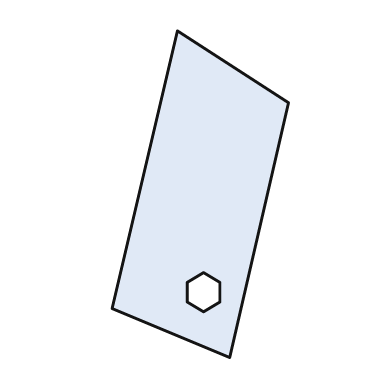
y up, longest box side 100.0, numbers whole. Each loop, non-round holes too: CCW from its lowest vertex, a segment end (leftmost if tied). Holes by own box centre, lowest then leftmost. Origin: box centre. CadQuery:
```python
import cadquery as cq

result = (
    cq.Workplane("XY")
    .moveTo(9.0, -50.0)
    .lineTo(27.0, 28.0)
    .lineTo(-7.0, 50.0)
    .lineTo(-27.0, -35.0)
    .close()
    .moveTo(1.0, -36.0)
    .lineTo(6.0, -33.0)
    .lineTo(6.0, -27.0)
    .lineTo(1.0, -24.0)
    .lineTo(-4.0, -27.0)
    .lineTo(-4.0, -33.0)
    .close()
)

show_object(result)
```